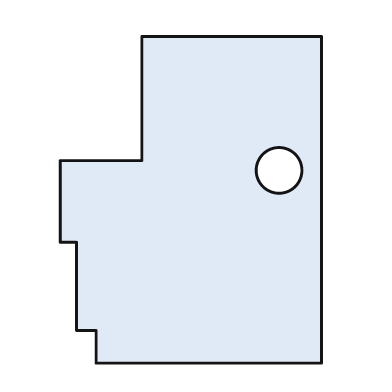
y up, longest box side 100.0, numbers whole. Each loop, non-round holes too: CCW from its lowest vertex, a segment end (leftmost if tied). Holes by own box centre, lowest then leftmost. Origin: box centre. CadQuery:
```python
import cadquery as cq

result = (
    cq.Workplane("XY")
    .moveTo(-29.0, -50.0)
    .lineTo(40.0, -50.0)
    .lineTo(40.0, 50.0)
    .lineTo(-15.0, 50.0)
    .lineTo(-15.0, 12.0)
    .lineTo(-40.0, 12.0)
    .lineTo(-40.0, -13.0)
    .lineTo(-35.0, -13.0)
    .lineTo(-35.0, -40.0)
    .lineTo(-29.0, -40.0)
    .close()
    .moveTo(27.0, 9.0)
    .circle(7.0)
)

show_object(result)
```